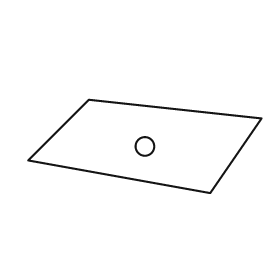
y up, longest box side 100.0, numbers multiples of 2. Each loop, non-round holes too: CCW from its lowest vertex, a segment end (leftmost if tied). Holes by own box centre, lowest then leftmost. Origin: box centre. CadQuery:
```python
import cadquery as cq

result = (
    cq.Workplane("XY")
    .moveTo(28.0, -20.0)
    .lineTo(50.0, 12.0)
    .lineTo(-24.0, 20.0)
    .lineTo(-50.0, -6.0)
    .close()
    .moveTo(0.0, 0.0)
    .circle(4.0)
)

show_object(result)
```